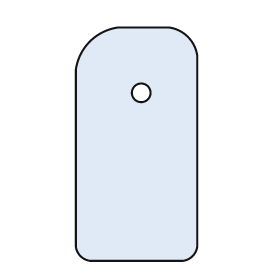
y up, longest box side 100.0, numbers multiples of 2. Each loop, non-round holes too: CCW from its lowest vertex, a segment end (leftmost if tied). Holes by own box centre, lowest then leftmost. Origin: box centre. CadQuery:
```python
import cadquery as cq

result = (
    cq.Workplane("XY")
    .moveTo(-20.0, -50.0)
    .lineTo(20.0, -50.0)
    .threePointArc((24.0, -48.0), (26.0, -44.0))
    .lineTo(26.0, 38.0)
    .threePointArc((22.0, 46.0), (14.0, 50.0))
    .lineTo(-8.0, 50.0)
    .threePointArc((-20.0, 44.0), (-26.0, 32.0))
    .lineTo(-26.0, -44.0)
    .threePointArc((-24.0, -48.0), (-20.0, -50.0))
    .close()
    .moveTo(2.0, 22.0)
    .circle(4.0)
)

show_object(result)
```